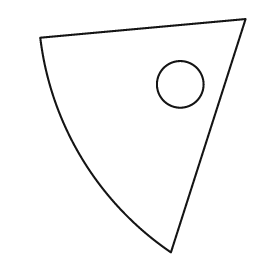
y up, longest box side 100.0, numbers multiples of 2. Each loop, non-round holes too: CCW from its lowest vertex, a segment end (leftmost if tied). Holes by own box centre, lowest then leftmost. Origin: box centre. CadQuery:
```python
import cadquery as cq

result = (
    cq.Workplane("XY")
    .moveTo(12.0, -50.0)
    .lineTo(44.0, 50.0)
    .lineTo(-44.0, 42.0)
    .threePointArc((-26.0, -10.0), (12.0, -50.0))
    .close()
    .moveTo(16.0, 22.0)
    .circle(10.0)
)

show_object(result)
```